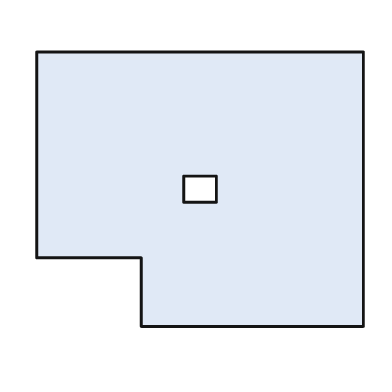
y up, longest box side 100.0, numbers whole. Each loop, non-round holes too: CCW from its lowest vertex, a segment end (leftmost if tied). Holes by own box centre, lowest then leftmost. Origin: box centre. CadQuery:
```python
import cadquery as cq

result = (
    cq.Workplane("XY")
    .moveTo(-18.0, -42.0)
    .lineTo(50.0, -42.0)
    .lineTo(50.0, 42.0)
    .lineTo(-50.0, 42.0)
    .lineTo(-50.0, -21.0)
    .lineTo(-18.0, -21.0)
    .close()
    .moveTo(-5.0, -4.0)
    .lineTo(5.0, -4.0)
    .lineTo(5.0, 4.0)
    .lineTo(-5.0, 4.0)
    .close()
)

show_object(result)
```